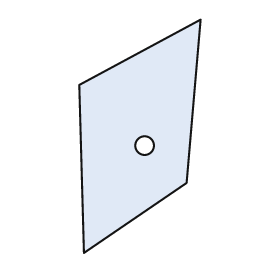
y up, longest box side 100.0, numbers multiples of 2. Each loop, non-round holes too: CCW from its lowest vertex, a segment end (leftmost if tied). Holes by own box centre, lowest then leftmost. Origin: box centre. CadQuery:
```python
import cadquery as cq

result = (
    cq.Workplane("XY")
    .moveTo(-24.0, -50.0)
    .lineTo(20.0, -20.0)
    .lineTo(26.0, 50.0)
    .lineTo(-26.0, 22.0)
    .close()
    .moveTo(2.0, -4.0)
    .circle(4.0)
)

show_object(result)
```